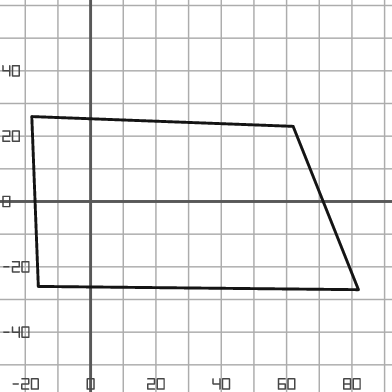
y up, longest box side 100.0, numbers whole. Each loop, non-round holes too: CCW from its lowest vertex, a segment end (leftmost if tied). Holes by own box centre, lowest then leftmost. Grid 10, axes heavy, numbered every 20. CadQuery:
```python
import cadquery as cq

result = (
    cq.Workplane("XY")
    .moveTo(82.0, -27.0)
    .lineTo(62.0, 23.0)
    .lineTo(-18.0, 26.0)
    .lineTo(-16.0, -26.0)
    .close()
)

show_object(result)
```